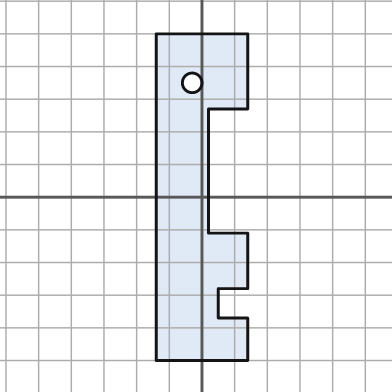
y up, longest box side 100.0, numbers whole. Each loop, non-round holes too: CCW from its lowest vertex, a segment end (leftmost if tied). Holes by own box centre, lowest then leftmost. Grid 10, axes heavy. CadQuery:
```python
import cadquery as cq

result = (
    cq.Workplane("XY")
    .moveTo(-14.0, -50.0)
    .lineTo(14.0, -50.0)
    .lineTo(14.0, -37.0)
    .lineTo(5.0, -37.0)
    .lineTo(5.0, -28.0)
    .lineTo(14.0, -28.0)
    .lineTo(14.0, -11.0)
    .lineTo(2.0, -11.0)
    .lineTo(2.0, 27.0)
    .lineTo(14.0, 27.0)
    .lineTo(14.0, 50.0)
    .lineTo(-14.0, 50.0)
    .close()
    .moveTo(-3.0, 35.0)
    .circle(3.0)
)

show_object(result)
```